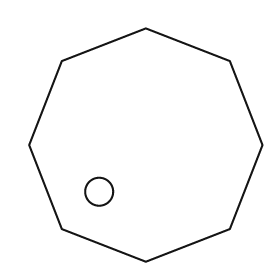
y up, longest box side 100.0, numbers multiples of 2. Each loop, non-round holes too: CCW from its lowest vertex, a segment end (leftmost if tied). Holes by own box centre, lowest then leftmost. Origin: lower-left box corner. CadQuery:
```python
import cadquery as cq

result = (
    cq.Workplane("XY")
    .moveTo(50.0, 0.0)
    .lineTo(86.0, 14.0)
    .lineTo(100.0, 50.0)
    .lineTo(86.0, 86.0)
    .lineTo(50.0, 100.0)
    .lineTo(14.0, 86.0)
    .lineTo(0.0, 50.0)
    .lineTo(14.0, 14.0)
    .close()
    .moveTo(30.0, 30.0)
    .circle(6.0)
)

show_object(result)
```